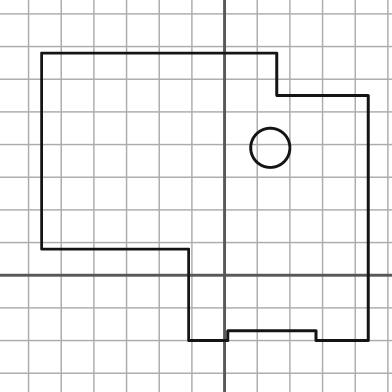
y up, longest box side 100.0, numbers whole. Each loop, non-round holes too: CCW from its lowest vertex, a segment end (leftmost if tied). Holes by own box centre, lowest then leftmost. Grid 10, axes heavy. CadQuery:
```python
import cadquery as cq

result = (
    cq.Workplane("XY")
    .moveTo(-11.0, -20.0)
    .lineTo(1.0, -20.0)
    .lineTo(1.0, -17.0)
    .lineTo(28.0, -17.0)
    .lineTo(28.0, -20.0)
    .lineTo(44.0, -20.0)
    .lineTo(44.0, 55.0)
    .lineTo(16.0, 55.0)
    .lineTo(16.0, 68.0)
    .lineTo(-56.0, 68.0)
    .lineTo(-56.0, 8.0)
    .lineTo(-11.0, 8.0)
    .close()
    .moveTo(14.0, 39.0)
    .circle(6.0)
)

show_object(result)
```